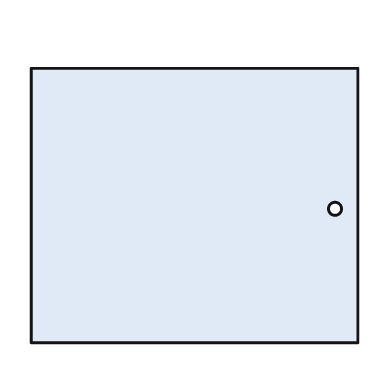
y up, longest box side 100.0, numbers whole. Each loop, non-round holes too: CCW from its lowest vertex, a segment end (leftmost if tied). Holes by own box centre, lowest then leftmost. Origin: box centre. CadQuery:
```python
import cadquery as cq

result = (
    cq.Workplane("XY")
    .moveTo(-50.0, -42.0)
    .lineTo(50.0, -42.0)
    .lineTo(50.0, 42.0)
    .lineTo(-50.0, 42.0)
    .close()
    .moveTo(43.0, -1.0)
    .circle(2.0)
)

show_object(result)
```